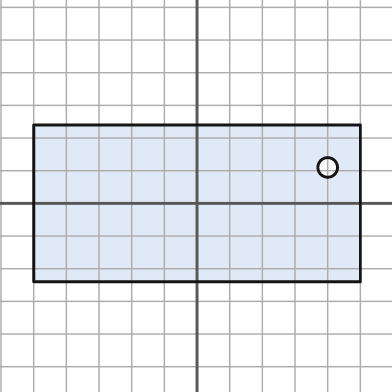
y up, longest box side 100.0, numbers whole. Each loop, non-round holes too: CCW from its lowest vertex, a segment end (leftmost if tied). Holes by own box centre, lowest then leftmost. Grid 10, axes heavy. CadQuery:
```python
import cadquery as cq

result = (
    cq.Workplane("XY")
    .moveTo(-50.0, -24.0)
    .lineTo(50.0, -24.0)
    .lineTo(50.0, 24.0)
    .lineTo(-50.0, 24.0)
    .close()
    .moveTo(40.0, 11.0)
    .circle(3.0)
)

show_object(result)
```